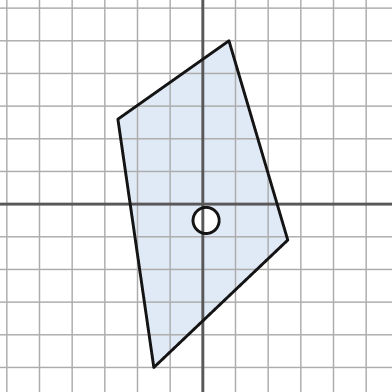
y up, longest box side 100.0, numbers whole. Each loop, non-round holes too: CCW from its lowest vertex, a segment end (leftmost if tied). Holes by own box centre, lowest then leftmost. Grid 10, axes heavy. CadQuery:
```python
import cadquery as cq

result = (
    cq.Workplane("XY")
    .moveTo(-15.0, -50.0)
    .lineTo(26.0, -11.0)
    .lineTo(8.0, 50.0)
    .lineTo(-26.0, 26.0)
    .close()
    .moveTo(1.0, -5.0)
    .circle(4.0)
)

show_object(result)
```